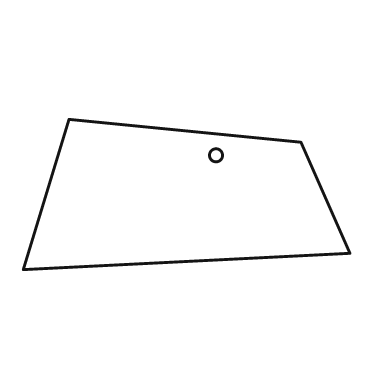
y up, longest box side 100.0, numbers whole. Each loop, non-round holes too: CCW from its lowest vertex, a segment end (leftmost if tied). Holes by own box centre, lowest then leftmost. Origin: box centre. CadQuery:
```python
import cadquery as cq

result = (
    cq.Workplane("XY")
    .moveTo(-50.0, -23.0)
    .lineTo(50.0, -18.0)
    .lineTo(35.0, 16.0)
    .lineTo(-36.0, 23.0)
    .close()
    .moveTo(9.0, 12.0)
    .circle(2.0)
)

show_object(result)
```